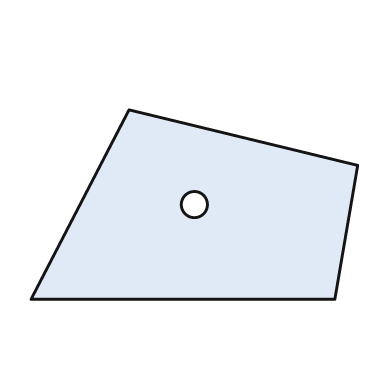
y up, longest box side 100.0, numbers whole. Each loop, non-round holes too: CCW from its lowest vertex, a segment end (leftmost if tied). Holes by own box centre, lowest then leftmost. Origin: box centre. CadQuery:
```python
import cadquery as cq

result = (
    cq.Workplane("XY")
    .moveTo(-50.0, -29.0)
    .lineTo(43.0, -29.0)
    .lineTo(50.0, 12.0)
    .lineTo(-20.0, 29.0)
    .close()
    .moveTo(0.0, 0.0)
    .circle(4.0)
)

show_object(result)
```